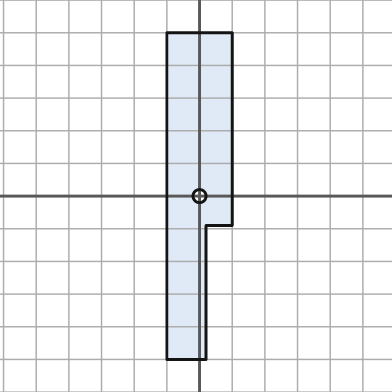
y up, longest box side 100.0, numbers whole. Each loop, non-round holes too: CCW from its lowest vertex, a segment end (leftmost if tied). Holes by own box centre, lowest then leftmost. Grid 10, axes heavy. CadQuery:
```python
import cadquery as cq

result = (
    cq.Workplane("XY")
    .moveTo(-10.0, -50.0)
    .lineTo(2.0, -50.0)
    .lineTo(2.0, -9.0)
    .lineTo(10.0, -9.0)
    .lineTo(10.0, 50.0)
    .lineTo(-10.0, 50.0)
    .close()
    .moveTo(0.0, 0.0)
    .circle(2.0)
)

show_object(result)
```